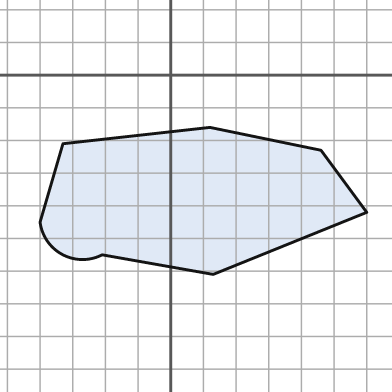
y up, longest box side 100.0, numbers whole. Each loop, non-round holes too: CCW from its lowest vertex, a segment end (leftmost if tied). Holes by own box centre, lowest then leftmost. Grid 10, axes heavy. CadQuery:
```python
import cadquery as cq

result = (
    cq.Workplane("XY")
    .moveTo(13.0, -61.0)
    .lineTo(60.0, -42.0)
    .lineTo(46.0, -23.0)
    .lineTo(12.0, -16.0)
    .lineTo(-33.0, -21.0)
    .lineTo(-40.0, -45.0)
    .threePointArc((-33.0, -55.0), (-21.0, -55.0))
    .close()
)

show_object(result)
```